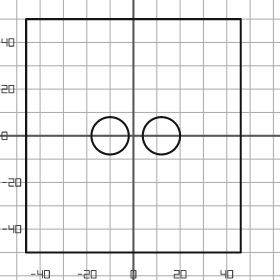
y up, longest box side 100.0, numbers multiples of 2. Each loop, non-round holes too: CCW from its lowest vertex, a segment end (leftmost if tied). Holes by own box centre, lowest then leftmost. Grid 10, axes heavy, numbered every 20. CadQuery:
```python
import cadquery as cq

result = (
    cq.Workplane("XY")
    .moveTo(-46.0, -50.0)
    .lineTo(46.0, -50.0)
    .lineTo(46.0, 50.0)
    .lineTo(-46.0, 50.0)
    .close()
    .moveTo(-10.0, 0.0)
    .circle(8.0)
    .moveTo(12.0, 0.0)
    .circle(8.0)
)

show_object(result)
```